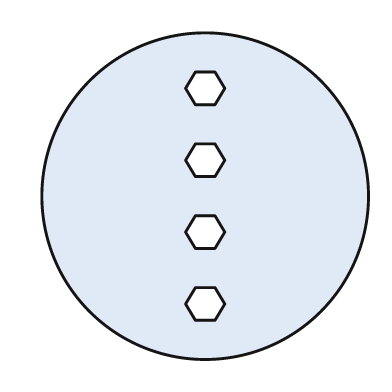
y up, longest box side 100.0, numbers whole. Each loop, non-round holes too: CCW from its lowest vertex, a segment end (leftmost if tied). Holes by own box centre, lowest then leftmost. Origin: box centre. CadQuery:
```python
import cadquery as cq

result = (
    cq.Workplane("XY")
    .moveTo(0.0, 0.0)
    .circle(50.0)
    .moveTo(-3.0, -38.0)
    .lineTo(3.0, -38.0)
    .lineTo(6.0, -33.0)
    .lineTo(3.0, -28.0)
    .lineTo(-3.0, -28.0)
    .lineTo(-6.0, -33.0)
    .close()
    .moveTo(-3.0, -16.0)
    .lineTo(3.0, -16.0)
    .lineTo(6.0, -11.0)
    .lineTo(3.0, -6.0)
    .lineTo(-3.0, -6.0)
    .lineTo(-6.0, -11.0)
    .close()
    .moveTo(-3.0, 6.0)
    .lineTo(3.0, 6.0)
    .lineTo(6.0, 11.0)
    .lineTo(3.0, 16.0)
    .lineTo(-3.0, 16.0)
    .lineTo(-6.0, 11.0)
    .close()
    .moveTo(-3.0, 28.0)
    .lineTo(3.0, 28.0)
    .lineTo(6.0, 33.0)
    .lineTo(3.0, 38.0)
    .lineTo(-3.0, 38.0)
    .lineTo(-6.0, 33.0)
    .close()
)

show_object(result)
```